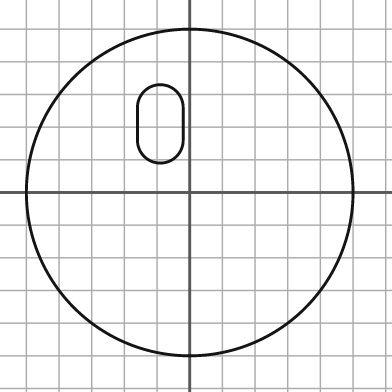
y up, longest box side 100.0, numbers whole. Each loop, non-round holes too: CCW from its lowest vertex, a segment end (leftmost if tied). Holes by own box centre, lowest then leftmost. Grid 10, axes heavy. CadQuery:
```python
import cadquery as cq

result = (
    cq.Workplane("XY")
    .moveTo(0.0, 0.0)
    .circle(50.0)
    .moveTo(-16.0, 16.0)
    .threePointArc((-9.0, 9.0), (-2.0, 16.0))
    .lineTo(-2.0, 26.0)
    .threePointArc((-9.0, 33.0), (-16.0, 26.0))
    .close()
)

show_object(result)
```